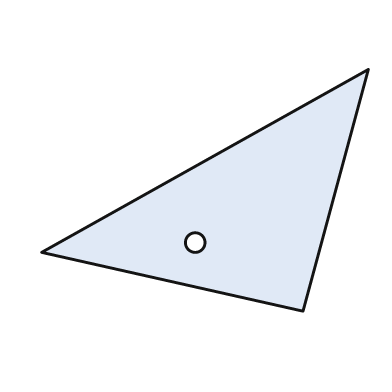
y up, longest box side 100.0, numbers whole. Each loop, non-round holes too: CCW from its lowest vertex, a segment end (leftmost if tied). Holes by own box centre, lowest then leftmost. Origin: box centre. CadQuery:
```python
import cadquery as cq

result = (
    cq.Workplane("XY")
    .moveTo(30.0, -37.0)
    .lineTo(50.0, 37.0)
    .lineTo(-50.0, -19.0)
    .close()
    .moveTo(-3.0, -16.0)
    .circle(3.0)
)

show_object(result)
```